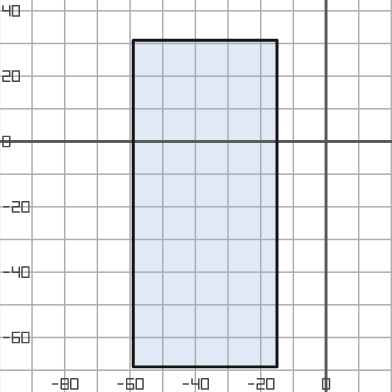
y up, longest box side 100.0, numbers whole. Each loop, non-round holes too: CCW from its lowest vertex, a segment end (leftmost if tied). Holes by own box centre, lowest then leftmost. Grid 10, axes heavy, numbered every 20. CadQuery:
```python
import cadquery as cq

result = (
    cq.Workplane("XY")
    .moveTo(-59.0, -69.0)
    .lineTo(-15.0, -69.0)
    .lineTo(-15.0, 31.0)
    .lineTo(-59.0, 31.0)
    .close()
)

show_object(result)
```